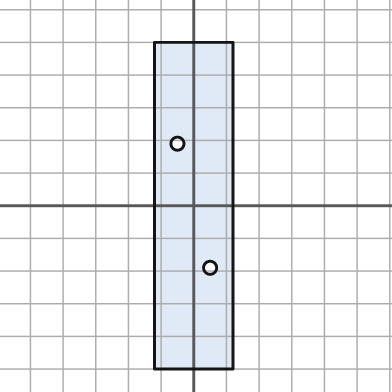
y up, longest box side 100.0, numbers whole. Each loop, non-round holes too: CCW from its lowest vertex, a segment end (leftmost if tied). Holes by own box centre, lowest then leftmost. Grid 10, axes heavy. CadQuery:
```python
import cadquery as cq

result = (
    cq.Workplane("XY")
    .moveTo(-12.0, -50.0)
    .lineTo(12.0, -50.0)
    .lineTo(12.0, 50.0)
    .lineTo(-12.0, 50.0)
    .close()
    .moveTo(5.0, -19.0)
    .circle(2.0)
    .moveTo(-5.0, 19.0)
    .circle(2.0)
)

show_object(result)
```